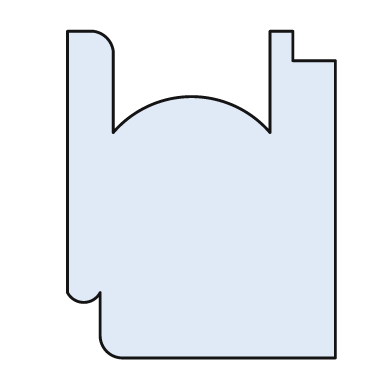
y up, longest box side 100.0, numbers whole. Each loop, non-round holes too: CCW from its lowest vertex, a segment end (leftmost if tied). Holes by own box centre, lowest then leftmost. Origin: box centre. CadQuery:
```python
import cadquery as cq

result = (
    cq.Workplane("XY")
    .moveTo(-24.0, -50.0)
    .lineTo(41.0, -50.0)
    .lineTo(41.0, 41.0)
    .lineTo(28.0, 41.0)
    .lineTo(28.0, 50.0)
    .lineTo(21.0, 50.0)
    .lineTo(21.0, 19.0)
    .threePointArc((-3.0, 30.0), (-27.0, 19.0))
    .lineTo(-27.0, 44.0)
    .threePointArc((-29.0, 48.0), (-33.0, 50.0))
    .lineTo(-41.0, 50.0)
    .lineTo(-41.0, -30.0)
    .threePointArc((-36.0, -33.0), (-31.0, -30.0))
    .lineTo(-31.0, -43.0)
    .threePointArc((-29.0, -48.0), (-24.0, -50.0))
    .close()
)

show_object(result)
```